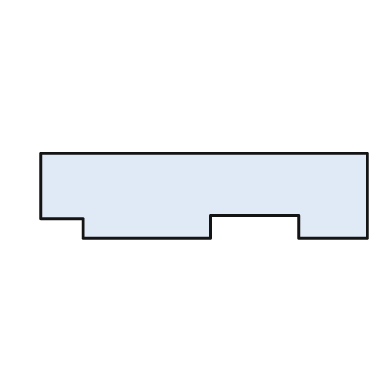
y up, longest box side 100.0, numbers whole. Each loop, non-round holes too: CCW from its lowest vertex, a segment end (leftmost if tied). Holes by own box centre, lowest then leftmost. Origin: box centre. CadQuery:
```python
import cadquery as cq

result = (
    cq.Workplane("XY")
    .moveTo(-37.0, -13.0)
    .lineTo(2.0, -13.0)
    .lineTo(2.0, -6.0)
    .lineTo(29.0, -6.0)
    .lineTo(29.0, -13.0)
    .lineTo(50.0, -13.0)
    .lineTo(50.0, 13.0)
    .lineTo(-50.0, 13.0)
    .lineTo(-50.0, -7.0)
    .lineTo(-37.0, -7.0)
    .close()
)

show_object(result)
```